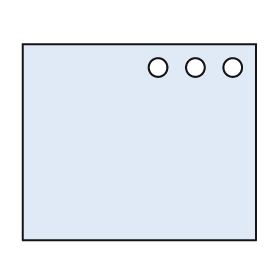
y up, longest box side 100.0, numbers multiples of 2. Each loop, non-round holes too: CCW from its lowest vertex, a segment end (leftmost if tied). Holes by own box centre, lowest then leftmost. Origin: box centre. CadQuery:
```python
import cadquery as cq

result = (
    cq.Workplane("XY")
    .moveTo(-50.0, -42.0)
    .lineTo(50.0, -42.0)
    .lineTo(50.0, 42.0)
    .lineTo(-50.0, 42.0)
    .close()
    .moveTo(8.0, 32.0)
    .circle(4.0)
    .moveTo(24.0, 32.0)
    .circle(4.0)
    .moveTo(40.0, 32.0)
    .circle(4.0)
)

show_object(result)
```